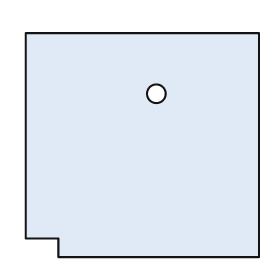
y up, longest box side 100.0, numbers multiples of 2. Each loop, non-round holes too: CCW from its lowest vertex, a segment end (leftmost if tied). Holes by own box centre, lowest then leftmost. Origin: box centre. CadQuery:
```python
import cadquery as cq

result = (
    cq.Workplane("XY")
    .moveTo(-36.0, -48.0)
    .lineTo(50.0, -48.0)
    .lineTo(50.0, 48.0)
    .lineTo(-50.0, 48.0)
    .lineTo(-50.0, -40.0)
    .lineTo(-36.0, -40.0)
    .close()
    .moveTo(6.0, 22.0)
    .circle(4.0)
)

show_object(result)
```